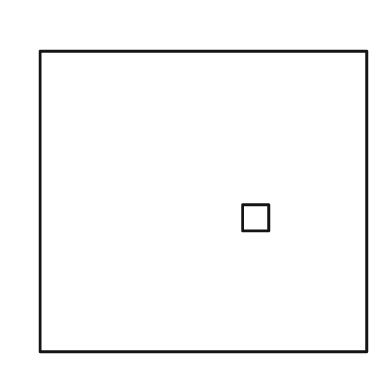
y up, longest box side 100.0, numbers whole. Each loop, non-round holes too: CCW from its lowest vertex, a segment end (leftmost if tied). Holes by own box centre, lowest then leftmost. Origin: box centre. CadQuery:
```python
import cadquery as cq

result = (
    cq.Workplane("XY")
    .moveTo(-50.0, -46.0)
    .lineTo(50.0, -46.0)
    .lineTo(50.0, 46.0)
    .lineTo(-50.0, 46.0)
    .close()
    .moveTo(12.0, -9.0)
    .lineTo(20.0, -9.0)
    .lineTo(20.0, -1.0)
    .lineTo(12.0, -1.0)
    .close()
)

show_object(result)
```